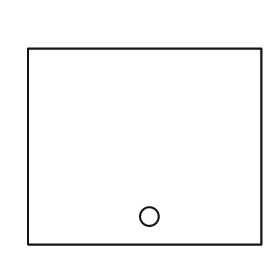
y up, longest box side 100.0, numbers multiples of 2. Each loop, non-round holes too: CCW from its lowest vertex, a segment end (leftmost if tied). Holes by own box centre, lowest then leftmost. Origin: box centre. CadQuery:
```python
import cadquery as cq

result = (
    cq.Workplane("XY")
    .moveTo(-50.0, -42.0)
    .lineTo(50.0, -42.0)
    .lineTo(50.0, 42.0)
    .lineTo(-50.0, 42.0)
    .close()
    .moveTo(2.0, -30.0)
    .circle(4.0)
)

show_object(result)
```